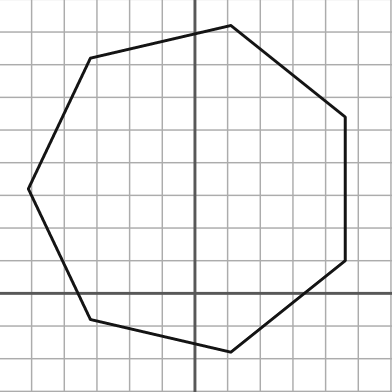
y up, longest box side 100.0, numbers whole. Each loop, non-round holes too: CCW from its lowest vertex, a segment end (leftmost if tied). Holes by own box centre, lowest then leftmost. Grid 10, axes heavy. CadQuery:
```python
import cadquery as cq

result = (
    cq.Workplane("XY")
    .moveTo(11.0, -18.0)
    .lineTo(46.0, 10.0)
    .lineTo(46.0, 54.0)
    .lineTo(11.0, 82.0)
    .lineTo(-32.0, 72.0)
    .lineTo(-51.0, 32.0)
    .lineTo(-32.0, -8.0)
    .close()
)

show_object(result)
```